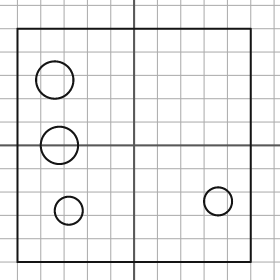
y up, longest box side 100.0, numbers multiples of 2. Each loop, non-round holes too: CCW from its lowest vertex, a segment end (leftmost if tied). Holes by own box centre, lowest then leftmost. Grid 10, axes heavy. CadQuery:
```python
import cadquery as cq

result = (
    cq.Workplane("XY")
    .moveTo(-50.0, -50.0)
    .lineTo(50.0, -50.0)
    .lineTo(50.0, 50.0)
    .lineTo(-50.0, 50.0)
    .close()
    .moveTo(-28.0, -28.0)
    .circle(6.0)
    .moveTo(36.0, -24.0)
    .circle(6.0)
    .moveTo(-32.0, 0.0)
    .circle(8.0)
    .moveTo(-34.0, 28.0)
    .circle(8.0)
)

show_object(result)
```